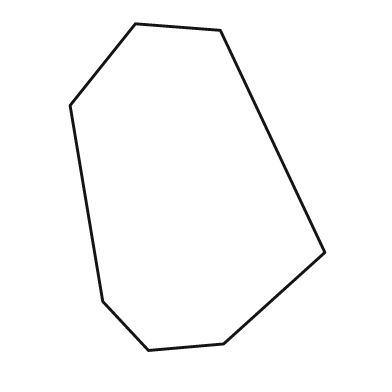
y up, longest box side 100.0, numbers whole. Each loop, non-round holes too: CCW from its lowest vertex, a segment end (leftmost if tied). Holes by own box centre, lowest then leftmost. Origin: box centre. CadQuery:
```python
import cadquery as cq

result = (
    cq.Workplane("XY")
    .moveTo(-15.0, -50.0)
    .lineTo(8.0, -48.0)
    .lineTo(39.0, -20.0)
    .lineTo(7.0, 48.0)
    .lineTo(-19.0, 50.0)
    .lineTo(-39.0, 25.0)
    .lineTo(-29.0, -35.0)
    .close()
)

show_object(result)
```